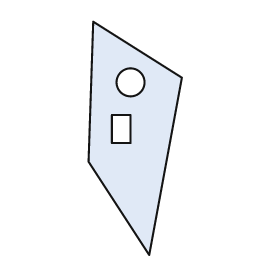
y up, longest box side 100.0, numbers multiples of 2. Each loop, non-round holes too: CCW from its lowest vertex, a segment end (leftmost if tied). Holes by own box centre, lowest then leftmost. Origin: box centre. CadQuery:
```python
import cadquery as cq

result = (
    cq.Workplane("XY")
    .moveTo(6.0, -50.0)
    .lineTo(20.0, 26.0)
    .lineTo(-18.0, 50.0)
    .lineTo(-20.0, -10.0)
    .close()
    .moveTo(-10.0, -2.0)
    .lineTo(-2.0, -2.0)
    .lineTo(-2.0, 10.0)
    .lineTo(-10.0, 10.0)
    .close()
    .moveTo(-2.0, 24.0)
    .circle(6.0)
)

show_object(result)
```